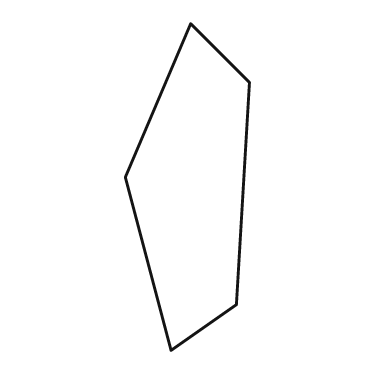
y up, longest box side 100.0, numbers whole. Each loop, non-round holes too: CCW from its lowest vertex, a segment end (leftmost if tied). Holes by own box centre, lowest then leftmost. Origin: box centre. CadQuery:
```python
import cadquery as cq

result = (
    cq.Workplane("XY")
    .moveTo(-5.0, -50.0)
    .lineTo(15.0, -36.0)
    .lineTo(19.0, 32.0)
    .lineTo(1.0, 50.0)
    .lineTo(-19.0, 3.0)
    .close()
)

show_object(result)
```